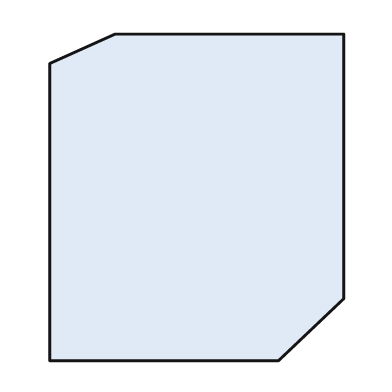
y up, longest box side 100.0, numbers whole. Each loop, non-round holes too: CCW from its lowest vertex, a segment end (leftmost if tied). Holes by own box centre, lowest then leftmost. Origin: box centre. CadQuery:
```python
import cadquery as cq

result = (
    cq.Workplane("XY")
    .moveTo(-45.0, -50.0)
    .lineTo(25.0, -50.0)
    .lineTo(45.0, -31.0)
    .lineTo(45.0, 50.0)
    .lineTo(-25.0, 50.0)
    .lineTo(-45.0, 41.0)
    .close()
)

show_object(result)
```